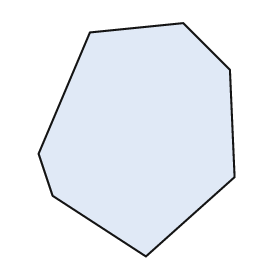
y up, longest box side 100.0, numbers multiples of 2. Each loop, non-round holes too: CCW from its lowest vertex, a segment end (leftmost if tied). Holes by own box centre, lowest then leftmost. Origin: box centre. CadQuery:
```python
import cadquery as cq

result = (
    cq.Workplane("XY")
    .moveTo(4.0, -50.0)
    .lineTo(42.0, -16.0)
    .lineTo(40.0, 30.0)
    .lineTo(20.0, 50.0)
    .lineTo(-20.0, 46.0)
    .lineTo(-42.0, -6.0)
    .lineTo(-36.0, -24.0)
    .close()
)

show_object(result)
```